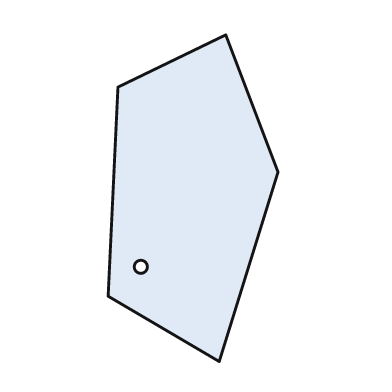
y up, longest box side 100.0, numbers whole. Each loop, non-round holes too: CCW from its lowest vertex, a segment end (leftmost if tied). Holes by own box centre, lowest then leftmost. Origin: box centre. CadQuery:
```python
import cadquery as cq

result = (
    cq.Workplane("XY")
    .moveTo(8.0, -50.0)
    .lineTo(26.0, 8.0)
    .lineTo(10.0, 50.0)
    .lineTo(-23.0, 34.0)
    .lineTo(-26.0, -30.0)
    .close()
    .moveTo(-16.0, -21.0)
    .circle(2.0)
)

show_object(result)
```